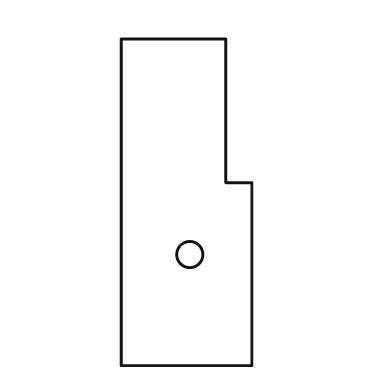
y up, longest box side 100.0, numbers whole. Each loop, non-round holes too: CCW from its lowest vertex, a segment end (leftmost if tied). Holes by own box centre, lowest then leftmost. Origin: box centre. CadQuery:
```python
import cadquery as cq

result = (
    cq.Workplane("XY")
    .moveTo(-20.0, -50.0)
    .lineTo(20.0, -50.0)
    .lineTo(20.0, 6.0)
    .lineTo(12.0, 6.0)
    .lineTo(12.0, 50.0)
    .lineTo(-20.0, 50.0)
    .close()
    .moveTo(1.0, -16.0)
    .circle(4.0)
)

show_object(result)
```